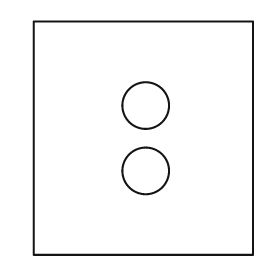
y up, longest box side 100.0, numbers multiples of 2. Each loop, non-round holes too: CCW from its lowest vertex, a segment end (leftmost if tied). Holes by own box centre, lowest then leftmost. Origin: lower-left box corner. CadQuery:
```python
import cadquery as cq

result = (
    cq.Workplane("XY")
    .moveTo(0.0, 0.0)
    .lineTo(94.0, 0.0)
    .lineTo(94.0, 100.0)
    .lineTo(0.0, 100.0)
    .close()
    .moveTo(48.0, 36.0)
    .circle(10.0)
    .moveTo(48.0, 64.0)
    .circle(10.0)
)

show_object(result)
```